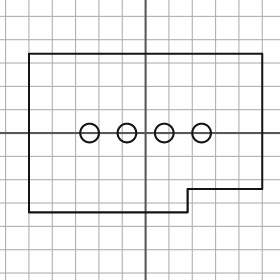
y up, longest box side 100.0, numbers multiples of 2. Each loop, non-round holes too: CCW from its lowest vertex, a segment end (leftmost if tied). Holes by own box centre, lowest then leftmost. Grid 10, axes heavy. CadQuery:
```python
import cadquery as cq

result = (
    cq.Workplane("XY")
    .moveTo(-50.0, -34.0)
    .lineTo(18.0, -34.0)
    .lineTo(18.0, -24.0)
    .lineTo(50.0, -24.0)
    .lineTo(50.0, 34.0)
    .lineTo(-50.0, 34.0)
    .close()
    .moveTo(-24.0, 0.0)
    .circle(4.0)
    .moveTo(-8.0, 0.0)
    .circle(4.0)
    .moveTo(8.0, 0.0)
    .circle(4.0)
    .moveTo(24.0, 0.0)
    .circle(4.0)
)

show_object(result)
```